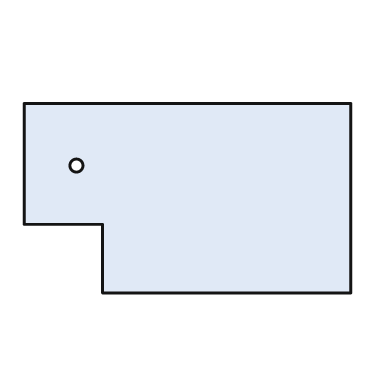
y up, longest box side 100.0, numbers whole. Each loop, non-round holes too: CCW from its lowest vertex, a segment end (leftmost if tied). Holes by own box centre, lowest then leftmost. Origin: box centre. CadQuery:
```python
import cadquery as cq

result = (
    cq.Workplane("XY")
    .moveTo(-26.0, -29.0)
    .lineTo(50.0, -29.0)
    .lineTo(50.0, 29.0)
    .lineTo(-50.0, 29.0)
    .lineTo(-50.0, -8.0)
    .lineTo(-26.0, -8.0)
    .close()
    .moveTo(-34.0, 10.0)
    .circle(2.0)
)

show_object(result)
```